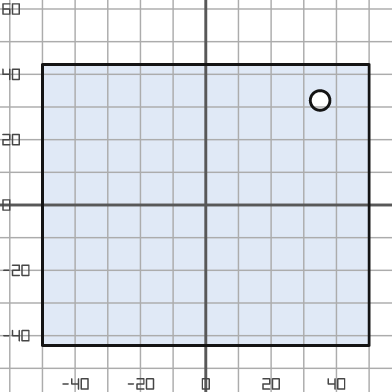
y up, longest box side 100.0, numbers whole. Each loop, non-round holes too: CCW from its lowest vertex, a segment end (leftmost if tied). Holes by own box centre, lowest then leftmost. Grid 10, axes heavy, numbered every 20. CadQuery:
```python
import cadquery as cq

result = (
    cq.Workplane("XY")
    .moveTo(-50.0, -43.0)
    .lineTo(50.0, -43.0)
    .lineTo(50.0, 43.0)
    .lineTo(-50.0, 43.0)
    .close()
    .moveTo(35.0, 32.0)
    .circle(3.0)
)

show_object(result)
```